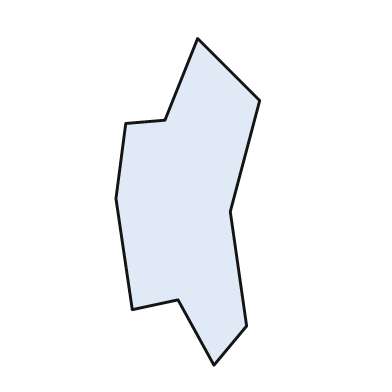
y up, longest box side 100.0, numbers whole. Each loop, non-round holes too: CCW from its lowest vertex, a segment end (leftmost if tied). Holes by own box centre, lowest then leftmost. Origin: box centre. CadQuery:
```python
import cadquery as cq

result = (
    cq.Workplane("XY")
    .moveTo(8.0, -50.0)
    .lineTo(18.0, -38.0)
    .lineTo(13.0, -3.0)
    .lineTo(22.0, 31.0)
    .lineTo(3.0, 50.0)
    .lineTo(-7.0, 25.0)
    .lineTo(-19.0, 24.0)
    .lineTo(-22.0, 1.0)
    .lineTo(-17.0, -33.0)
    .lineTo(-3.0, -30.0)
    .close()
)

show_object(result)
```